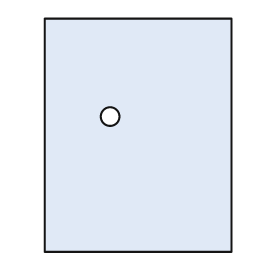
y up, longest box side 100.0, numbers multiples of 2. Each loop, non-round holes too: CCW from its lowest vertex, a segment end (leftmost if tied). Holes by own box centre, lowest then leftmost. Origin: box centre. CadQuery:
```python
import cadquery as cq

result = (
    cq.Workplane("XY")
    .moveTo(-40.0, -50.0)
    .lineTo(40.0, -50.0)
    .lineTo(40.0, 50.0)
    .lineTo(-40.0, 50.0)
    .close()
    .moveTo(-12.0, 8.0)
    .circle(4.0)
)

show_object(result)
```